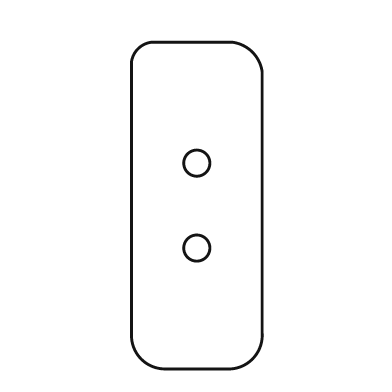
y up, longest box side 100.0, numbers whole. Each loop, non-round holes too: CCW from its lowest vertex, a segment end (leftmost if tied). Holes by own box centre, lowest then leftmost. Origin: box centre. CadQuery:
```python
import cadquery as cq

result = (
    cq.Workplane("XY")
    .moveTo(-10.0, -50.0)
    .lineTo(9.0, -50.0)
    .threePointArc((17.0, -47.0), (20.0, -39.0))
    .lineTo(20.0, 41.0)
    .threePointArc((17.0, 47.0), (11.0, 50.0))
    .lineTo(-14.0, 50.0)
    .threePointArc((-18.0, 48.0), (-20.0, 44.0))
    .lineTo(-20.0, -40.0)
    .threePointArc((-17.0, -47.0), (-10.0, -50.0))
    .close()
    .moveTo(0.0, -13.0)
    .circle(4.0)
    .moveTo(0.0, 13.0)
    .circle(4.0)
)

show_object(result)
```